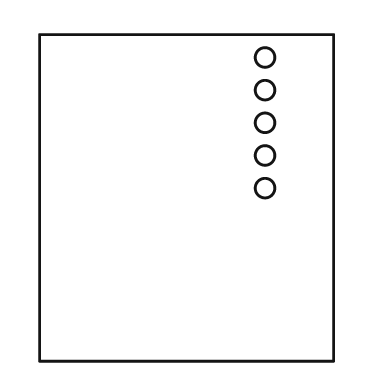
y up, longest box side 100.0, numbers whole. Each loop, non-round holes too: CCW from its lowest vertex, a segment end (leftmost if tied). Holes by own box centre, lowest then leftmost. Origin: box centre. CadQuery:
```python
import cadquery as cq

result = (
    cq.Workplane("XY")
    .moveTo(-45.0, -50.0)
    .lineTo(45.0, -50.0)
    .lineTo(45.0, 50.0)
    .lineTo(-45.0, 50.0)
    .close()
    .moveTo(24.0, 3.0)
    .circle(3.0)
    .moveTo(24.0, 13.0)
    .circle(3.0)
    .moveTo(24.0, 23.0)
    .circle(3.0)
    .moveTo(24.0, 33.0)
    .circle(3.0)
    .moveTo(24.0, 43.0)
    .circle(3.0)
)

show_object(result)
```